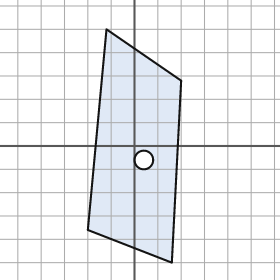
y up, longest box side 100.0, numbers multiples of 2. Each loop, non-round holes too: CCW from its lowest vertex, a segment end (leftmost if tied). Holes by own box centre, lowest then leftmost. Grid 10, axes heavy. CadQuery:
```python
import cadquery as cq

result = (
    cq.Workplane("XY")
    .moveTo(16.0, -50.0)
    .lineTo(20.0, 28.0)
    .lineTo(-12.0, 50.0)
    .lineTo(-20.0, -36.0)
    .close()
    .moveTo(4.0, -6.0)
    .circle(4.0)
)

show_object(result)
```